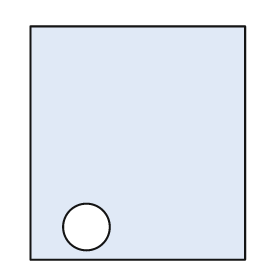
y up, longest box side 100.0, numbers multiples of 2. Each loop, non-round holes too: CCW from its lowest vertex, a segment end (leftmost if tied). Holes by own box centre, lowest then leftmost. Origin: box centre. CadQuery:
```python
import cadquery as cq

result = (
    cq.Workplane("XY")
    .moveTo(-46.0, -50.0)
    .lineTo(46.0, -50.0)
    .lineTo(46.0, 50.0)
    .lineTo(-46.0, 50.0)
    .close()
    .moveTo(-22.0, -36.0)
    .circle(10.0)
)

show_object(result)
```